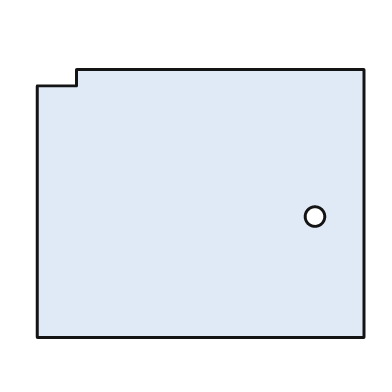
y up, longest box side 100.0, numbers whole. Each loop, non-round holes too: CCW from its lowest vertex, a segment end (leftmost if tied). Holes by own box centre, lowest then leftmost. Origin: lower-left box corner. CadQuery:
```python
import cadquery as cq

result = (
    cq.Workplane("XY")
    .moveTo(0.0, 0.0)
    .lineTo(100.0, 0.0)
    .lineTo(100.0, 82.0)
    .lineTo(12.0, 82.0)
    .lineTo(12.0, 77.0)
    .lineTo(0.0, 77.0)
    .close()
    .moveTo(85.0, 37.0)
    .circle(3.0)
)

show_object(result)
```